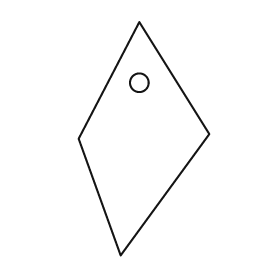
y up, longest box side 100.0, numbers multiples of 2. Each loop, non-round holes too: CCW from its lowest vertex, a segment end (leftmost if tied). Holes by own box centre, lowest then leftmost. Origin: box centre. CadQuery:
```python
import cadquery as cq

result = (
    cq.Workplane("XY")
    .moveTo(-10.0, -50.0)
    .lineTo(28.0, 2.0)
    .lineTo(-2.0, 50.0)
    .lineTo(-28.0, 0.0)
    .close()
    .moveTo(-2.0, 24.0)
    .circle(4.0)
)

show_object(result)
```